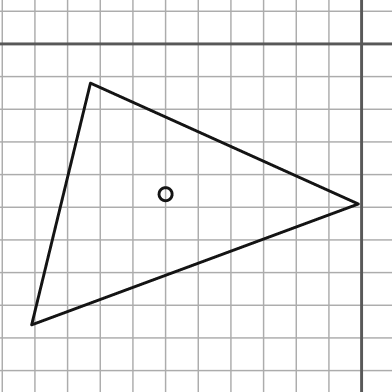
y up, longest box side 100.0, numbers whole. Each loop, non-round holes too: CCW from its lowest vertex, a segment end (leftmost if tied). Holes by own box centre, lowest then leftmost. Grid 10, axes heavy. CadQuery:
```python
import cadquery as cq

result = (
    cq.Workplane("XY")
    .moveTo(-101.0, -86.0)
    .lineTo(-1.0, -49.0)
    .lineTo(-83.0, -12.0)
    .close()
    .moveTo(-60.0, -46.0)
    .circle(2.0)
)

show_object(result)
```